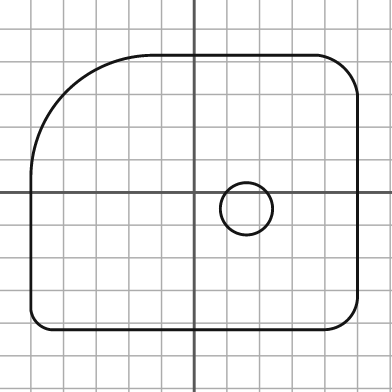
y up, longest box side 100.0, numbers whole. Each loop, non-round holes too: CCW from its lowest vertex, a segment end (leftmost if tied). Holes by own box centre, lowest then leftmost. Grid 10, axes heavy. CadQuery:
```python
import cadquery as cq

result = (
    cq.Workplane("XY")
    .moveTo(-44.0, -42.0)
    .lineTo(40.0, -42.0)
    .threePointArc((47.0, -39.0), (50.0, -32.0))
    .lineTo(50.0, 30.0)
    .threePointArc((46.0, 38.0), (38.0, 42.0))
    .lineTo(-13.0, 42.0)
    .threePointArc((-39.0, 31.0), (-50.0, 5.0))
    .lineTo(-50.0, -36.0)
    .threePointArc((-48.0, -40.0), (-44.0, -42.0))
    .close()
    .moveTo(16.0, -5.0)
    .circle(8.0)
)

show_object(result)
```